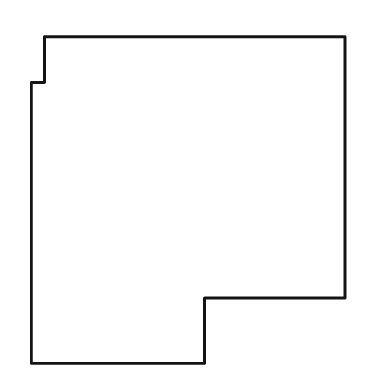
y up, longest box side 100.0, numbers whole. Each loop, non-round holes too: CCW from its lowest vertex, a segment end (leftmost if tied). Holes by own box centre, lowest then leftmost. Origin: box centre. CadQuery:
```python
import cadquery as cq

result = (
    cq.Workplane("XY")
    .moveTo(-48.0, -50.0)
    .lineTo(5.0, -50.0)
    .lineTo(5.0, -30.0)
    .lineTo(48.0, -30.0)
    .lineTo(48.0, 50.0)
    .lineTo(-44.0, 50.0)
    .lineTo(-44.0, 36.0)
    .lineTo(-48.0, 36.0)
    .close()
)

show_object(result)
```